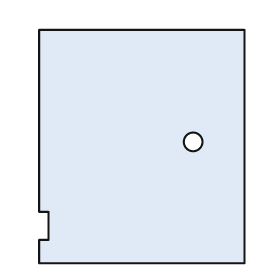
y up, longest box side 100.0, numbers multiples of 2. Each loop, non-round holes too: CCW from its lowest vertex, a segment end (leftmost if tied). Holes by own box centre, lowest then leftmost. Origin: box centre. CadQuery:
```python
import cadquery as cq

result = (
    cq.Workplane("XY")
    .moveTo(-44.0, -50.0)
    .lineTo(44.0, -50.0)
    .lineTo(44.0, 50.0)
    .lineTo(-44.0, 50.0)
    .lineTo(-44.0, -28.0)
    .lineTo(-40.0, -28.0)
    .lineTo(-40.0, -40.0)
    .lineTo(-44.0, -40.0)
    .close()
    .moveTo(22.0, 2.0)
    .circle(4.0)
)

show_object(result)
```